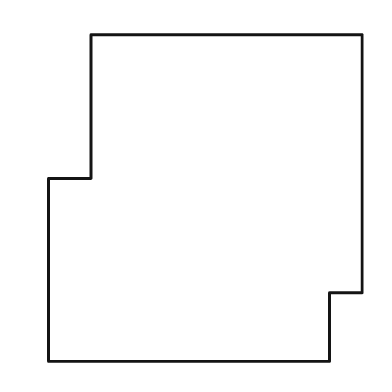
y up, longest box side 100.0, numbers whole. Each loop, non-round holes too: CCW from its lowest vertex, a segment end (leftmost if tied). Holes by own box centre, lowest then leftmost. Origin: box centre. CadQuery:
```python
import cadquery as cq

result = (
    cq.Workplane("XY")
    .moveTo(-48.0, -50.0)
    .lineTo(38.0, -50.0)
    .lineTo(38.0, -29.0)
    .lineTo(48.0, -29.0)
    .lineTo(48.0, 50.0)
    .lineTo(-35.0, 50.0)
    .lineTo(-35.0, 6.0)
    .lineTo(-48.0, 6.0)
    .close()
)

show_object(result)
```